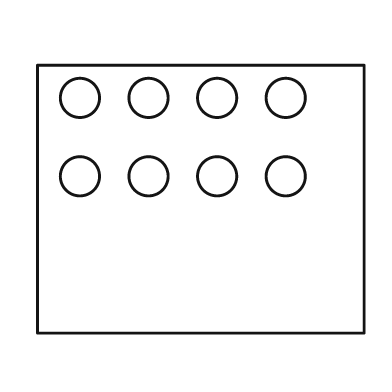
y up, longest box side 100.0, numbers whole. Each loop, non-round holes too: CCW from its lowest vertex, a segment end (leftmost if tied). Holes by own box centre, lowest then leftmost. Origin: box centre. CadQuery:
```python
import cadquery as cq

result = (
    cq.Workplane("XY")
    .moveTo(-50.0, -41.0)
    .lineTo(50.0, -41.0)
    .lineTo(50.0, 41.0)
    .lineTo(-50.0, 41.0)
    .close()
    .moveTo(-37.0, 7.0)
    .circle(6.0)
    .moveTo(-16.0, 7.0)
    .circle(6.0)
    .moveTo(5.0, 7.0)
    .circle(6.0)
    .moveTo(26.0, 7.0)
    .circle(6.0)
    .moveTo(-37.0, 31.0)
    .circle(6.0)
    .moveTo(-16.0, 31.0)
    .circle(6.0)
    .moveTo(5.0, 31.0)
    .circle(6.0)
    .moveTo(26.0, 31.0)
    .circle(6.0)
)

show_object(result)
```